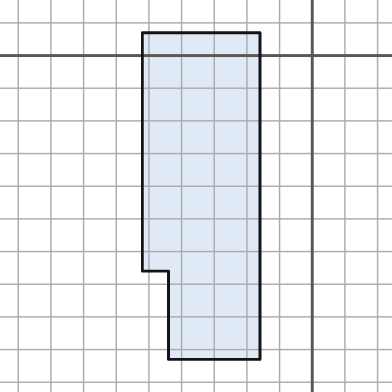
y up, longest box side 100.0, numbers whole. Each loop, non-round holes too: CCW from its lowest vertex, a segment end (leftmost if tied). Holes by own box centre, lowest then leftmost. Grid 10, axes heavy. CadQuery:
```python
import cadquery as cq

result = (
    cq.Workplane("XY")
    .moveTo(-44.0, -93.0)
    .lineTo(-16.0, -93.0)
    .lineTo(-16.0, 7.0)
    .lineTo(-52.0, 7.0)
    .lineTo(-52.0, -66.0)
    .lineTo(-44.0, -66.0)
    .close()
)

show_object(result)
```